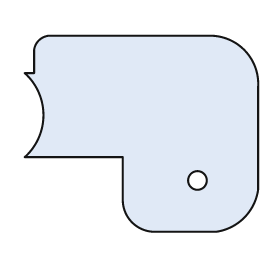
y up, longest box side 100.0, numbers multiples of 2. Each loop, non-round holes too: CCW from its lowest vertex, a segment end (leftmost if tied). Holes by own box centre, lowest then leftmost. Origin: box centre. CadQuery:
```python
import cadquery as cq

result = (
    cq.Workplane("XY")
    .moveTo(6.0, -42.0)
    .lineTo(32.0, -42.0)
    .threePointArc((44.0, -36.0), (50.0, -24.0))
    .lineTo(50.0, 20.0)
    .threePointArc((44.0, 36.0), (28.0, 42.0))
    .lineTo(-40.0, 42.0)
    .threePointArc((-44.0, 40.0), (-46.0, 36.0))
    .lineTo(-46.0, 26.0)
    .lineTo(-50.0, 26.0)
    .threePointArc((-42.0, 8.0), (-50.0, -10.0))
    .lineTo(-8.0, -10.0)
    .lineTo(-8.0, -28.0)
    .threePointArc((-4.0, -38.0), (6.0, -42.0))
    .close()
    .moveTo(24.0, -20.0)
    .circle(4.0)
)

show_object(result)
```